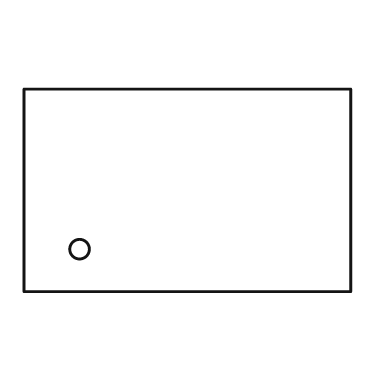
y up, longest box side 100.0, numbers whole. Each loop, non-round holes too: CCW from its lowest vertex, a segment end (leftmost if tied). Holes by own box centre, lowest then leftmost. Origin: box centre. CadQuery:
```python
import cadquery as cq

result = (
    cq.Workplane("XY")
    .moveTo(-50.0, -31.0)
    .lineTo(50.0, -31.0)
    .lineTo(50.0, 31.0)
    .lineTo(-50.0, 31.0)
    .close()
    .moveTo(-33.0, -18.0)
    .circle(3.0)
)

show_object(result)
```